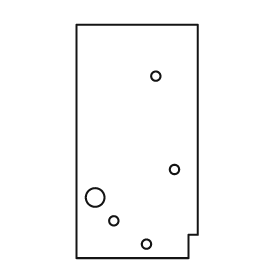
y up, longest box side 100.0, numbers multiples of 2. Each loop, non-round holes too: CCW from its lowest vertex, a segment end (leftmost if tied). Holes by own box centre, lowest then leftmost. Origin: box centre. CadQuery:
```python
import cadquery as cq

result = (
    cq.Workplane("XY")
    .moveTo(-26.0, -50.0)
    .lineTo(22.0, -50.0)
    .lineTo(22.0, -40.0)
    .lineTo(26.0, -40.0)
    .lineTo(26.0, 50.0)
    .lineTo(-26.0, 50.0)
    .close()
    .moveTo(4.0, -44.0)
    .circle(2.0)
    .moveTo(-10.0, -34.0)
    .circle(2.0)
    .moveTo(-18.0, -24.0)
    .circle(4.0)
    .moveTo(16.0, -12.0)
    .circle(2.0)
    .moveTo(8.0, 28.0)
    .circle(2.0)
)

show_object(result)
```